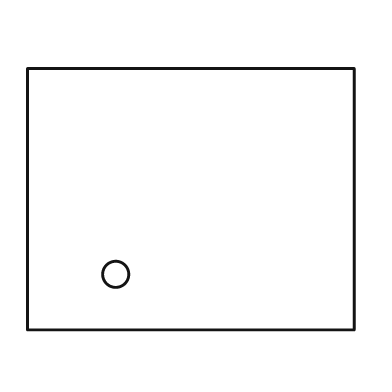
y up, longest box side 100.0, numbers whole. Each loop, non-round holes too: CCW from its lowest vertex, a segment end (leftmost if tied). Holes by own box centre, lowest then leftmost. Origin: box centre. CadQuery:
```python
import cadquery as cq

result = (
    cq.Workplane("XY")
    .moveTo(-50.0, -40.0)
    .lineTo(50.0, -40.0)
    .lineTo(50.0, 40.0)
    .lineTo(-50.0, 40.0)
    .close()
    .moveTo(-23.0, -23.0)
    .circle(4.0)
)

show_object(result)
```